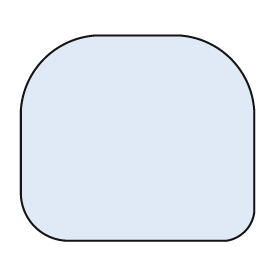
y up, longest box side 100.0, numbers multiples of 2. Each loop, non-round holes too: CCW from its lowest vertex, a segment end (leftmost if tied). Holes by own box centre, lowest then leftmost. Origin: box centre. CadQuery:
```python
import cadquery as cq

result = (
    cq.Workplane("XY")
    .moveTo(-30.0, -44.0)
    .lineTo(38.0, -44.0)
    .threePointArc((46.0, -40.0), (50.0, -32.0))
    .lineTo(50.0, 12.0)
    .threePointArc((40.0, 34.0), (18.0, 44.0))
    .lineTo(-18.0, 44.0)
    .threePointArc((-40.0, 34.0), (-50.0, 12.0))
    .lineTo(-50.0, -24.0)
    .threePointArc((-44.0, -38.0), (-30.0, -44.0))
    .close()
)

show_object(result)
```